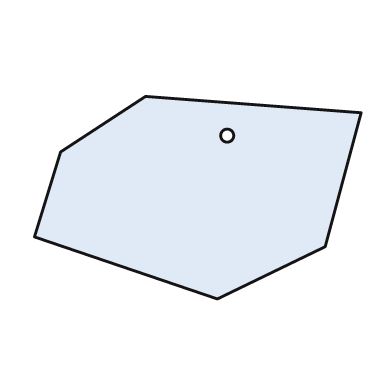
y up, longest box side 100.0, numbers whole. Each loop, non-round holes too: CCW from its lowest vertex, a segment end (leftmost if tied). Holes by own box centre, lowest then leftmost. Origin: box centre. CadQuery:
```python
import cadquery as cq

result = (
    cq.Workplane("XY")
    .moveTo(6.0, -31.0)
    .lineTo(39.0, -15.0)
    .lineTo(50.0, 26.0)
    .lineTo(-16.0, 31.0)
    .lineTo(-42.0, 14.0)
    .lineTo(-50.0, -12.0)
    .close()
    .moveTo(9.0, 19.0)
    .circle(2.0)
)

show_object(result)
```